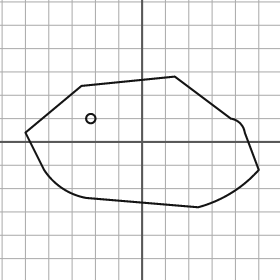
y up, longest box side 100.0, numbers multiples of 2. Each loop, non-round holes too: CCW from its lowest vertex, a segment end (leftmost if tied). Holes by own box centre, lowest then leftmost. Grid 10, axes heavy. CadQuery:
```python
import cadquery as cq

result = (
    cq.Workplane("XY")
    .moveTo(24.0, -28.0)
    .threePointArc((38.0, -22.0), (50.0, -12.0))
    .lineTo(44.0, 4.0)
    .threePointArc((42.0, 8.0), (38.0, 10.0))
    .lineTo(14.0, 28.0)
    .lineTo(-26.0, 24.0)
    .lineTo(-50.0, 4.0)
    .lineTo(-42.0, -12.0)
    .threePointArc((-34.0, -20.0), (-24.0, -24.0))
    .close()
    .moveTo(-22.0, 10.0)
    .circle(2.0)
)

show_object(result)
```